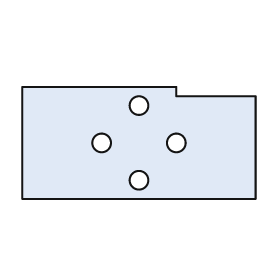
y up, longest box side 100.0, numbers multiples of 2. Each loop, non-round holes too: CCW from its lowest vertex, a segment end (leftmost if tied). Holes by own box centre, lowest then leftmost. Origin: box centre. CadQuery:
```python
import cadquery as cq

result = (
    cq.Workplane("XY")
    .moveTo(-50.0, -24.0)
    .lineTo(50.0, -24.0)
    .lineTo(50.0, 20.0)
    .lineTo(16.0, 20.0)
    .lineTo(16.0, 24.0)
    .lineTo(-50.0, 24.0)
    .close()
    .moveTo(0.0, -16.0)
    .circle(4.0)
    .moveTo(-16.0, 0.0)
    .circle(4.0)
    .moveTo(16.0, 0.0)
    .circle(4.0)
    .moveTo(0.0, 16.0)
    .circle(4.0)
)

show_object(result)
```